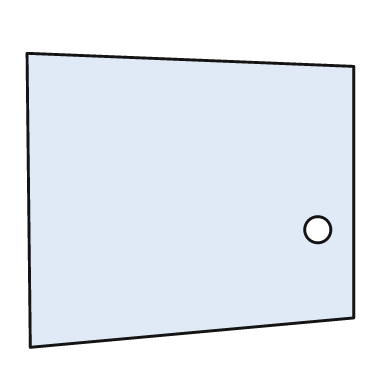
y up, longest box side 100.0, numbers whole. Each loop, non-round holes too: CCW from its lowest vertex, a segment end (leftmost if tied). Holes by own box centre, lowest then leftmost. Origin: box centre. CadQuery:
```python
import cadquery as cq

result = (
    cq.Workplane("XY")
    .moveTo(-49.0, -45.0)
    .lineTo(50.0, -36.0)
    .lineTo(50.0, 41.0)
    .lineTo(-50.0, 45.0)
    .close()
    .moveTo(39.0, -9.0)
    .circle(4.0)
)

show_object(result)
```